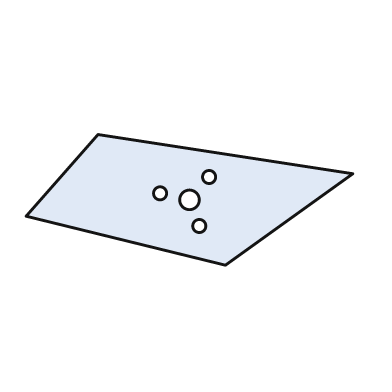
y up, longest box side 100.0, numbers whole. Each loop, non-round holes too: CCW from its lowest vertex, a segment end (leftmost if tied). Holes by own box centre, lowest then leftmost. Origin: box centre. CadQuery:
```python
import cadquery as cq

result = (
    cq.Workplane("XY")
    .moveTo(11.0, -20.0)
    .lineTo(50.0, 8.0)
    .lineTo(-28.0, 20.0)
    .lineTo(-50.0, -5.0)
    .close()
    .moveTo(3.0, -8.0)
    .circle(2.0)
    .moveTo(0.0, 0.0)
    .circle(3.0)
    .moveTo(-9.0, 2.0)
    .circle(2.0)
    .moveTo(6.0, 7.0)
    .circle(2.0)
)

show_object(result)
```